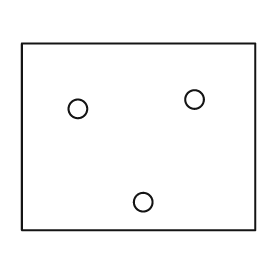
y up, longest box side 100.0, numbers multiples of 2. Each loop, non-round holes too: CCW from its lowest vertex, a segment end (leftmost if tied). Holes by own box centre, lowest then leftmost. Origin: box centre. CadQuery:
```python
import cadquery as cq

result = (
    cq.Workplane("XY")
    .moveTo(-50.0, -40.0)
    .lineTo(50.0, -40.0)
    .lineTo(50.0, 40.0)
    .lineTo(-50.0, 40.0)
    .close()
    .moveTo(2.0, -28.0)
    .circle(4.0)
    .moveTo(-26.0, 12.0)
    .circle(4.0)
    .moveTo(24.0, 16.0)
    .circle(4.0)
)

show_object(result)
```